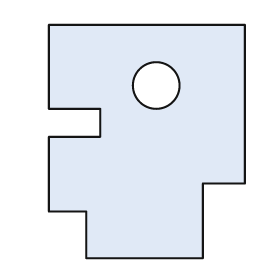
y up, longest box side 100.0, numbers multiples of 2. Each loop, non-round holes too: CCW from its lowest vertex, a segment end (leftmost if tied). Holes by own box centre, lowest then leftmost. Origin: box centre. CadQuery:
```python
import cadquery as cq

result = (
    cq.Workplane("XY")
    .moveTo(-26.0, -50.0)
    .lineTo(24.0, -50.0)
    .lineTo(24.0, -18.0)
    .lineTo(42.0, -18.0)
    .lineTo(42.0, 50.0)
    .lineTo(-42.0, 50.0)
    .lineTo(-42.0, 14.0)
    .lineTo(-20.0, 14.0)
    .lineTo(-20.0, 2.0)
    .lineTo(-42.0, 2.0)
    .lineTo(-42.0, -30.0)
    .lineTo(-26.0, -30.0)
    .close()
    .moveTo(4.0, 24.0)
    .circle(10.0)
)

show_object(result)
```